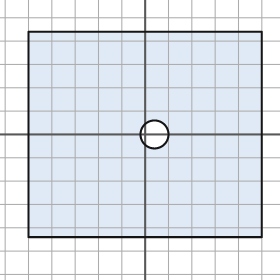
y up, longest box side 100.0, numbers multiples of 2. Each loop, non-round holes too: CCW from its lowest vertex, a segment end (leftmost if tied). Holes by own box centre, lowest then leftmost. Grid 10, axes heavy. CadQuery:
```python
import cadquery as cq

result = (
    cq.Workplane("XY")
    .moveTo(-50.0, -44.0)
    .lineTo(50.0, -44.0)
    .lineTo(50.0, 44.0)
    .lineTo(-50.0, 44.0)
    .close()
    .moveTo(4.0, 0.0)
    .circle(6.0)
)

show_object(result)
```